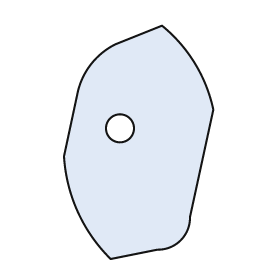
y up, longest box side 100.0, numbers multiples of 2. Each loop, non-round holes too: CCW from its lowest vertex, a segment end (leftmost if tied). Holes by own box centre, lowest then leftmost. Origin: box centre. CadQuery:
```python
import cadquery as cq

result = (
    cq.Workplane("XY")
    .moveTo(-12.0, -50.0)
    .lineTo(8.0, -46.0)
    .threePointArc((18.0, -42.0), (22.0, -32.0))
    .lineTo(32.0, 14.0)
    .threePointArc((24.0, 34.0), (10.0, 50.0))
    .lineTo(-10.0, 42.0)
    .threePointArc((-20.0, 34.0), (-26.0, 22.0))
    .lineTo(-32.0, -6.0)
    .threePointArc((-26.0, -30.0), (-12.0, -50.0))
    .close()
    .moveTo(-8.0, 6.0)
    .circle(6.0)
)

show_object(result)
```